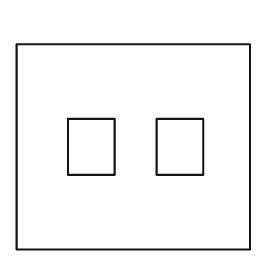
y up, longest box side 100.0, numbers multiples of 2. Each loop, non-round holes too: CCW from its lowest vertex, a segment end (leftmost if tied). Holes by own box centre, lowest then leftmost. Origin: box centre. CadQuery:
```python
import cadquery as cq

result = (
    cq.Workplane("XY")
    .moveTo(-50.0, -44.0)
    .lineTo(50.0, -44.0)
    .lineTo(50.0, 44.0)
    .lineTo(-50.0, 44.0)
    .close()
    .moveTo(-28.0, -12.0)
    .lineTo(-8.0, -12.0)
    .lineTo(-8.0, 12.0)
    .lineTo(-28.0, 12.0)
    .close()
    .moveTo(10.0, -12.0)
    .lineTo(30.0, -12.0)
    .lineTo(30.0, 12.0)
    .lineTo(10.0, 12.0)
    .close()
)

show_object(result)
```